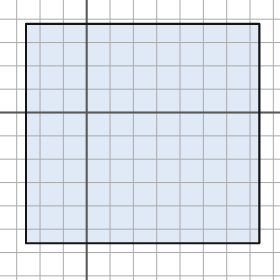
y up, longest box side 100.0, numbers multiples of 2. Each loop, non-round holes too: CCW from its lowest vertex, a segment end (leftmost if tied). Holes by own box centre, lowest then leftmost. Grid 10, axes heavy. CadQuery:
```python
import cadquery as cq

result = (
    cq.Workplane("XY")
    .moveTo(-26.0, -56.0)
    .lineTo(74.0, -56.0)
    .lineTo(74.0, 38.0)
    .lineTo(-26.0, 38.0)
    .close()
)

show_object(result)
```